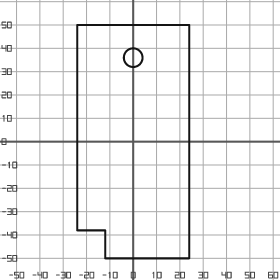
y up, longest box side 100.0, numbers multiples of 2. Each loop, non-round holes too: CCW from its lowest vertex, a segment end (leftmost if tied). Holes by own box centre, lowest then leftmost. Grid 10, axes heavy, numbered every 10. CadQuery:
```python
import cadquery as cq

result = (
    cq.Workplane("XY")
    .moveTo(-12.0, -50.0)
    .lineTo(24.0, -50.0)
    .lineTo(24.0, 50.0)
    .lineTo(-24.0, 50.0)
    .lineTo(-24.0, -38.0)
    .lineTo(-12.0, -38.0)
    .close()
    .moveTo(0.0, 36.0)
    .circle(4.0)
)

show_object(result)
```